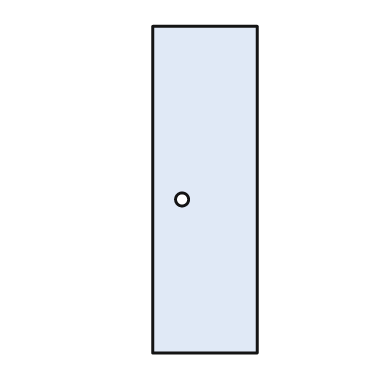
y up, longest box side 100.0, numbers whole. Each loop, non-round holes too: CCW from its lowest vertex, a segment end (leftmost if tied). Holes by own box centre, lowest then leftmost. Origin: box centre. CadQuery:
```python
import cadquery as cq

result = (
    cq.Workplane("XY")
    .moveTo(-16.0, -50.0)
    .lineTo(16.0, -50.0)
    .lineTo(16.0, 50.0)
    .lineTo(-16.0, 50.0)
    .close()
    .moveTo(-7.0, -3.0)
    .circle(2.0)
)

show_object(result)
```